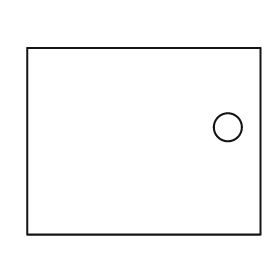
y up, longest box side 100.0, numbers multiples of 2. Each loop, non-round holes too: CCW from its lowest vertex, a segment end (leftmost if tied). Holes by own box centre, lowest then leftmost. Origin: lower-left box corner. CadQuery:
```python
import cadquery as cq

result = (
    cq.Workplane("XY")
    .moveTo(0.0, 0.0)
    .lineTo(100.0, 0.0)
    .lineTo(100.0, 80.0)
    .lineTo(0.0, 80.0)
    .close()
    .moveTo(86.0, 46.0)
    .circle(6.0)
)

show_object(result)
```